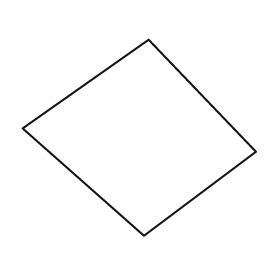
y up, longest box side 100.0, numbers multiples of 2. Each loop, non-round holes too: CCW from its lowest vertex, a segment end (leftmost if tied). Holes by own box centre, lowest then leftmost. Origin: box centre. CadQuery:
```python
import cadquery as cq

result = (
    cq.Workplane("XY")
    .moveTo(2.0, -42.0)
    .lineTo(50.0, -6.0)
    .lineTo(4.0, 42.0)
    .lineTo(-50.0, 4.0)
    .close()
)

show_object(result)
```